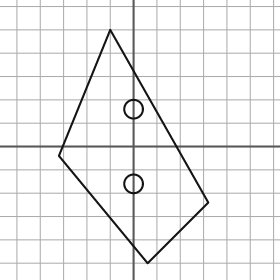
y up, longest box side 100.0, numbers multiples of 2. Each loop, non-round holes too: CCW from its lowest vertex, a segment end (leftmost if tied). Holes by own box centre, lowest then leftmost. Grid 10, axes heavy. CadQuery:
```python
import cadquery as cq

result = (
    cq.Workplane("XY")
    .moveTo(6.0, -50.0)
    .lineTo(32.0, -24.0)
    .lineTo(-10.0, 50.0)
    .lineTo(-32.0, -4.0)
    .close()
    .moveTo(0.0, -16.0)
    .circle(4.0)
    .moveTo(0.0, 16.0)
    .circle(4.0)
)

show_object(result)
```